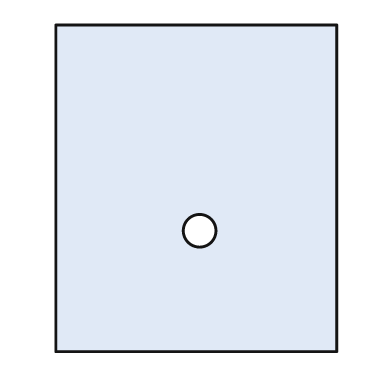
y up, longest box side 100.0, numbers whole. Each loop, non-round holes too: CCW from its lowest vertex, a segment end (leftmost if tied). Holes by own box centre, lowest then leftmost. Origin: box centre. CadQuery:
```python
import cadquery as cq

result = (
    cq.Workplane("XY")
    .moveTo(-43.0, -50.0)
    .lineTo(43.0, -50.0)
    .lineTo(43.0, 50.0)
    .lineTo(-43.0, 50.0)
    .close()
    .moveTo(1.0, -13.0)
    .circle(5.0)
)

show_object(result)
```